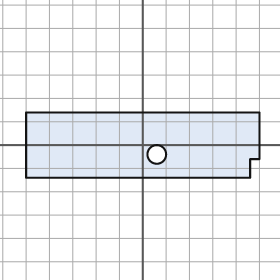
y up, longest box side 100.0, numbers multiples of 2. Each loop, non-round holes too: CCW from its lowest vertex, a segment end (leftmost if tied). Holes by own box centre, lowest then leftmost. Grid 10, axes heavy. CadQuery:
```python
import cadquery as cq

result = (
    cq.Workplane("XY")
    .moveTo(-50.0, -14.0)
    .lineTo(46.0, -14.0)
    .lineTo(46.0, -6.0)
    .lineTo(50.0, -6.0)
    .lineTo(50.0, 14.0)
    .lineTo(-50.0, 14.0)
    .close()
    .moveTo(6.0, -4.0)
    .circle(4.0)
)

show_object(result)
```